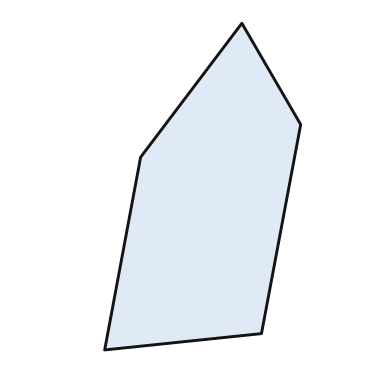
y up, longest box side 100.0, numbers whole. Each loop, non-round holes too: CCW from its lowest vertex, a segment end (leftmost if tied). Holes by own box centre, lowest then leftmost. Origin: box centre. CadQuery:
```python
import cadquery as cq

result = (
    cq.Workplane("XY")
    .moveTo(-30.0, -50.0)
    .lineTo(18.0, -45.0)
    .lineTo(30.0, 19.0)
    .lineTo(12.0, 50.0)
    .lineTo(-19.0, 9.0)
    .close()
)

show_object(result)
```